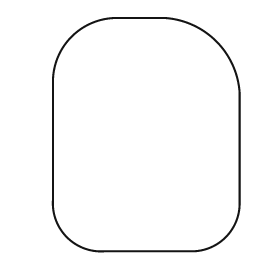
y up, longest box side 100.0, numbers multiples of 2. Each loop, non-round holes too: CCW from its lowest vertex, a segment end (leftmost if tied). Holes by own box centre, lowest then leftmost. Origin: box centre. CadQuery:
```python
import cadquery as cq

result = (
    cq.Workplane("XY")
    .moveTo(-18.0, -50.0)
    .lineTo(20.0, -50.0)
    .threePointArc((34.0, -44.0), (40.0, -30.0))
    .lineTo(40.0, 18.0)
    .threePointArc((30.0, 40.0), (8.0, 50.0))
    .lineTo(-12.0, 50.0)
    .threePointArc((-32.0, 42.0), (-40.0, 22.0))
    .lineTo(-40.0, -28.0)
    .threePointArc((-34.0, -44.0), (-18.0, -50.0))
    .close()
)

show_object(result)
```